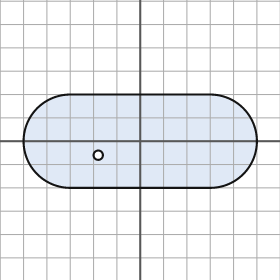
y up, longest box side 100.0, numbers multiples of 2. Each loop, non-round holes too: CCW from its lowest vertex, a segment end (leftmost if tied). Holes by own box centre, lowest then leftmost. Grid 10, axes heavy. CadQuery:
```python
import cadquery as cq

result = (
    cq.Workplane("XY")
    .moveTo(-30.0, -20.0)
    .lineTo(30.0, -20.0)
    .threePointArc((50.0, 0.0), (30.0, 20.0))
    .lineTo(-30.0, 20.0)
    .threePointArc((-50.0, 0.0), (-30.0, -20.0))
    .close()
    .moveTo(-18.0, -6.0)
    .circle(2.0)
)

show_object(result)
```